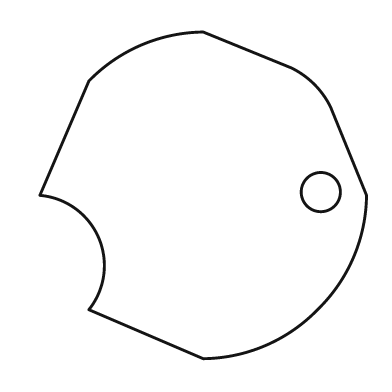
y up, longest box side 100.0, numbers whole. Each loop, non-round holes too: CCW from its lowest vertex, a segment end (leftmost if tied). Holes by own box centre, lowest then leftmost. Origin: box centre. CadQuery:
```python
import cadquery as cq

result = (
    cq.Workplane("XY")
    .moveTo(0.0, -50.0)
    .threePointArc((19.0, -46.0), (35.0, -35.0))
    .threePointArc((46.0, -19.0), (50.0, 0.0))
    .lineTo(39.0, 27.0)
    .threePointArc((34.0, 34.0), (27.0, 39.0))
    .lineTo(0.0, 50.0)
    .threePointArc((-19.0, 46.0), (-35.0, 35.0))
    .lineTo(-50.0, 0.0)
    .threePointArc((-32.0, -13.0), (-35.0, -35.0))
    .close()
    .moveTo(36.0, 1.0)
    .circle(6.0)
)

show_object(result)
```